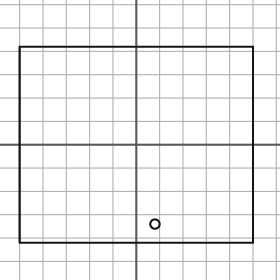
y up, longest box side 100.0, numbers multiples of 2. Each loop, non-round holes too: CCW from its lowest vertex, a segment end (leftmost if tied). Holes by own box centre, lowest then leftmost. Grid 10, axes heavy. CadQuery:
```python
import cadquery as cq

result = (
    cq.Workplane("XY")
    .moveTo(-50.0, -42.0)
    .lineTo(50.0, -42.0)
    .lineTo(50.0, 42.0)
    .lineTo(-50.0, 42.0)
    .close()
    .moveTo(8.0, -34.0)
    .circle(2.0)
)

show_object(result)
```